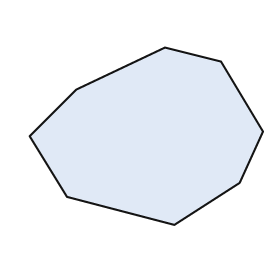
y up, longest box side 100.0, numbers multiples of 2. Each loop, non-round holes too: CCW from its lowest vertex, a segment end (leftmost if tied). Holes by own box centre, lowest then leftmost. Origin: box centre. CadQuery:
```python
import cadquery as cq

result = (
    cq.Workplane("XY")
    .moveTo(12.0, -38.0)
    .lineTo(40.0, -20.0)
    .lineTo(50.0, 2.0)
    .lineTo(32.0, 32.0)
    .lineTo(8.0, 38.0)
    .lineTo(-30.0, 20.0)
    .lineTo(-50.0, 0.0)
    .lineTo(-34.0, -26.0)
    .close()
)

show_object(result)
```